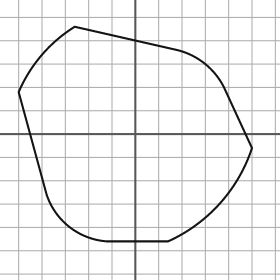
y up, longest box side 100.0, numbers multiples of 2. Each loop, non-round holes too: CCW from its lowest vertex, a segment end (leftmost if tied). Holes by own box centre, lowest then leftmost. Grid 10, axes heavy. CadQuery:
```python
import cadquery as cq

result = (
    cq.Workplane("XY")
    .moveTo(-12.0, -46.0)
    .lineTo(14.0, -46.0)
    .threePointArc((36.0, -30.0), (50.0, -6.0))
    .lineTo(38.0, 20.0)
    .threePointArc((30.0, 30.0), (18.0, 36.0))
    .lineTo(-26.0, 46.0)
    .threePointArc((-40.0, 34.0), (-50.0, 18.0))
    .lineTo(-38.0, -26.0)
    .threePointArc((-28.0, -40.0), (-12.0, -46.0))
    .close()
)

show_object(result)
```